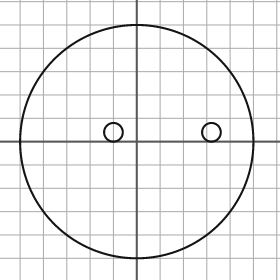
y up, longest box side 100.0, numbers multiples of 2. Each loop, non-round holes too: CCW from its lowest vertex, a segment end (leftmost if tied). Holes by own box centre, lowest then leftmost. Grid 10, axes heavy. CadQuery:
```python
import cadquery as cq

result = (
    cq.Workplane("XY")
    .moveTo(0.0, 0.0)
    .circle(50.0)
    .moveTo(-10.0, 4.0)
    .circle(4.0)
    .moveTo(32.0, 4.0)
    .circle(4.0)
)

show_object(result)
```